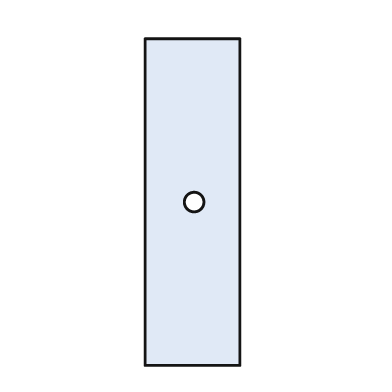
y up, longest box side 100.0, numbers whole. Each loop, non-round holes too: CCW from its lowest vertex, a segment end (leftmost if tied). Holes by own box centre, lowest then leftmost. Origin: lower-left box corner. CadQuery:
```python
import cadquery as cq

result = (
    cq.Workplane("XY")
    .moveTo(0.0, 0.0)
    .lineTo(29.0, 0.0)
    .lineTo(29.0, 100.0)
    .lineTo(0.0, 100.0)
    .close()
    .moveTo(15.0, 50.0)
    .circle(3.0)
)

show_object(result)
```